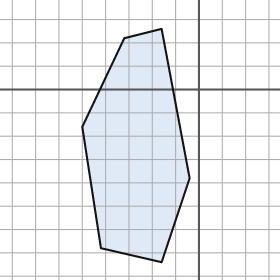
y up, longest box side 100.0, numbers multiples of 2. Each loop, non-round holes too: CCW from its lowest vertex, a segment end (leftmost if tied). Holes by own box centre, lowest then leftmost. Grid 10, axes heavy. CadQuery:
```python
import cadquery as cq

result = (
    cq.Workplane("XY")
    .moveTo(-16.0, -74.0)
    .lineTo(-4.0, -38.0)
    .lineTo(-16.0, 26.0)
    .lineTo(-32.0, 22.0)
    .lineTo(-50.0, -16.0)
    .lineTo(-42.0, -68.0)
    .close()
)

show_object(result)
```